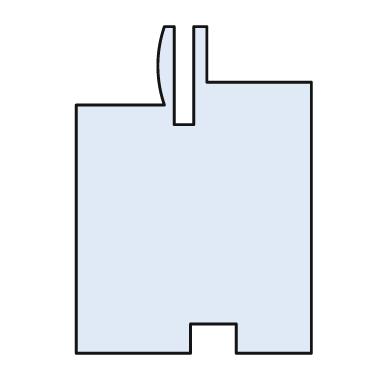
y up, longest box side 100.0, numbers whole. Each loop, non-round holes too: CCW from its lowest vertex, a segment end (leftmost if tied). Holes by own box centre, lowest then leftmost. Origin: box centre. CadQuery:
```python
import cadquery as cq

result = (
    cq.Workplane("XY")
    .moveTo(-36.0, -50.0)
    .lineTo(-1.0, -50.0)
    .lineTo(-1.0, -41.0)
    .lineTo(13.0, -41.0)
    .lineTo(13.0, -50.0)
    .lineTo(36.0, -50.0)
    .lineTo(36.0, 33.0)
    .lineTo(4.0, 33.0)
    .lineTo(4.0, 50.0)
    .lineTo(0.0, 50.0)
    .lineTo(0.0, 20.0)
    .lineTo(-6.0, 20.0)
    .lineTo(-6.0, 50.0)
    .lineTo(-9.0, 50.0)
    .threePointArc((-11.0, 38.0), (-9.0, 26.0))
    .lineTo(-36.0, 26.0)
    .close()
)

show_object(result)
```